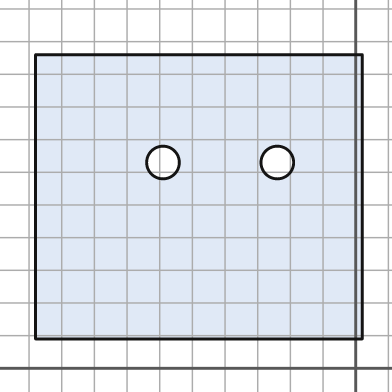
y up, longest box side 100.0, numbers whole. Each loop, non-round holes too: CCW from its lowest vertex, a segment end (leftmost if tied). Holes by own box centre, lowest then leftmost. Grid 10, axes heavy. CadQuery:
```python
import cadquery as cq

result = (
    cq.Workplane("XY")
    .moveTo(-98.0, 9.0)
    .lineTo(2.0, 9.0)
    .lineTo(2.0, 96.0)
    .lineTo(-98.0, 96.0)
    .close()
    .moveTo(-59.0, 63.0)
    .circle(5.0)
    .moveTo(-24.0, 63.0)
    .circle(5.0)
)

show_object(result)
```